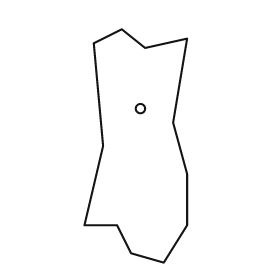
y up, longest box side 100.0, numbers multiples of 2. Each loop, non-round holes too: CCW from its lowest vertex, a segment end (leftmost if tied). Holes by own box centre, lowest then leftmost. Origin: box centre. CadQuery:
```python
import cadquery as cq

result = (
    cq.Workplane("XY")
    .moveTo(12.0, -50.0)
    .lineTo(22.0, -34.0)
    .lineTo(22.0, -12.0)
    .lineTo(16.0, 10.0)
    .lineTo(22.0, 46.0)
    .lineTo(4.0, 42.0)
    .lineTo(-6.0, 50.0)
    .lineTo(-18.0, 44.0)
    .lineTo(-14.0, 0.0)
    .lineTo(-22.0, -34.0)
    .lineTo(-8.0, -34.0)
    .lineTo(-2.0, -46.0)
    .close()
    .moveTo(2.0, 16.0)
    .circle(2.0)
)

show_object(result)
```